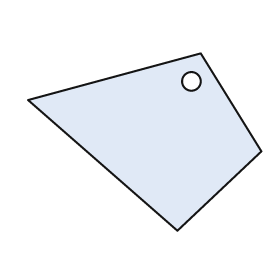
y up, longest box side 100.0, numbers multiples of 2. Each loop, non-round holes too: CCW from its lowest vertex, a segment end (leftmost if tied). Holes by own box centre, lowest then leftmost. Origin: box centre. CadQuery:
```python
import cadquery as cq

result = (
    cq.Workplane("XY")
    .moveTo(14.0, -38.0)
    .lineTo(50.0, -4.0)
    .lineTo(24.0, 38.0)
    .lineTo(-50.0, 18.0)
    .close()
    .moveTo(20.0, 26.0)
    .circle(4.0)
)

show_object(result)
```